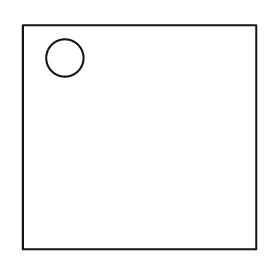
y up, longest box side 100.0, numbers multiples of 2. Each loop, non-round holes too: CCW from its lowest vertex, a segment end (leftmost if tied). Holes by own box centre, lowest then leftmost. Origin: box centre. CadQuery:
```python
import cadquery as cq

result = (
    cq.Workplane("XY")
    .moveTo(-50.0, -48.0)
    .lineTo(50.0, -48.0)
    .lineTo(50.0, 48.0)
    .lineTo(-50.0, 48.0)
    .close()
    .moveTo(-32.0, 34.0)
    .circle(8.0)
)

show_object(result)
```